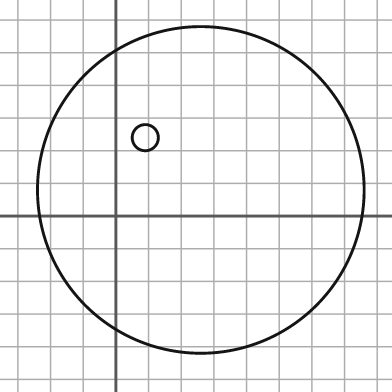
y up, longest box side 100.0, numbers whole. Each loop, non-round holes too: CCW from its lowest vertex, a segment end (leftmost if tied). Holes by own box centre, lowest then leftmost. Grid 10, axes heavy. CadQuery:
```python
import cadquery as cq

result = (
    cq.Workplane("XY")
    .moveTo(26.0, 8.0)
    .circle(50.0)
    .moveTo(9.0, 24.0)
    .circle(4.0)
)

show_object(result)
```